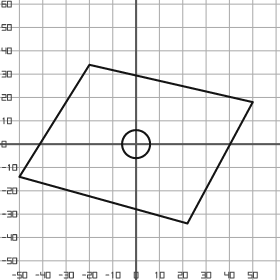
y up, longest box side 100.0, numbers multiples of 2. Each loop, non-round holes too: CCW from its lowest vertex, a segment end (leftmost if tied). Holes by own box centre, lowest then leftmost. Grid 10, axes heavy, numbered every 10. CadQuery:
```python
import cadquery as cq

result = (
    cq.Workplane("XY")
    .moveTo(22.0, -34.0)
    .lineTo(50.0, 18.0)
    .lineTo(-20.0, 34.0)
    .lineTo(-50.0, -14.0)
    .close()
    .moveTo(0.0, 0.0)
    .circle(6.0)
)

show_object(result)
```